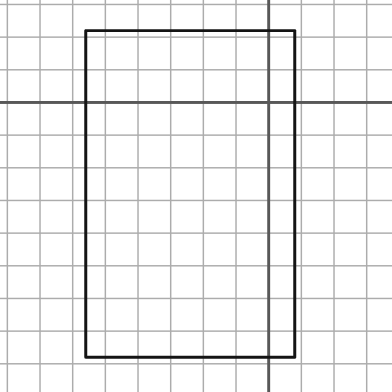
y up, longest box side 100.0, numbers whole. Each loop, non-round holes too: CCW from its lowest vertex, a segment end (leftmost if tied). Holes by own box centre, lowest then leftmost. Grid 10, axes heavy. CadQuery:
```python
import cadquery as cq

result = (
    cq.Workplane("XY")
    .moveTo(-56.0, -78.0)
    .lineTo(8.0, -78.0)
    .lineTo(8.0, 22.0)
    .lineTo(-56.0, 22.0)
    .close()
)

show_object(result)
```